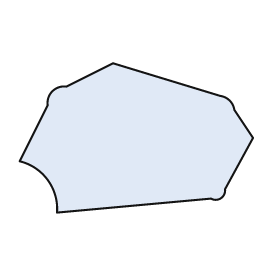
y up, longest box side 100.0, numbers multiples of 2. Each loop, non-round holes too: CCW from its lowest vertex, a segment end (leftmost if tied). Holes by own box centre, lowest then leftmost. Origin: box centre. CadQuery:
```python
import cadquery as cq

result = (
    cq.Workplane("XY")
    .moveTo(-34.0, -32.0)
    .lineTo(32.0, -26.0)
    .threePointArc((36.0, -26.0), (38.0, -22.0))
    .lineTo(50.0, 0.0)
    .lineTo(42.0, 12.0)
    .threePointArc((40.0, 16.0), (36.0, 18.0))
    .lineTo(-10.0, 32.0)
    .lineTo(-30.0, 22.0)
    .threePointArc((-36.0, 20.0), (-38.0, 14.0))
    .lineTo(-50.0, -10.0)
    .threePointArc((-38.0, -18.0), (-34.0, -32.0))
    .close()
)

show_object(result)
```